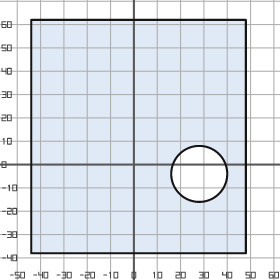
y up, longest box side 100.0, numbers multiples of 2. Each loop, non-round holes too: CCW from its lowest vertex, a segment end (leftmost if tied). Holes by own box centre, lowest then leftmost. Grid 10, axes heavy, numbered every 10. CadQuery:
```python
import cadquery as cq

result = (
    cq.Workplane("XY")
    .moveTo(-44.0, -38.0)
    .lineTo(48.0, -38.0)
    .lineTo(48.0, 62.0)
    .lineTo(-44.0, 62.0)
    .close()
    .moveTo(28.0, -4.0)
    .circle(12.0)
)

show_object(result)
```